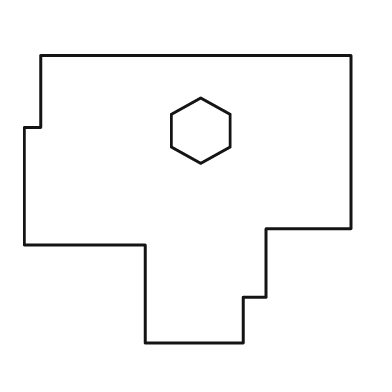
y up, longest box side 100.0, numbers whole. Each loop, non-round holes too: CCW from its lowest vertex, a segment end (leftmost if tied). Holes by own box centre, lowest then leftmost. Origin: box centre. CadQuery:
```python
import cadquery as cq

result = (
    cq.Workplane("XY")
    .moveTo(-13.0, -44.0)
    .lineTo(17.0, -44.0)
    .lineTo(17.0, -30.0)
    .lineTo(24.0, -30.0)
    .lineTo(24.0, -9.0)
    .lineTo(50.0, -9.0)
    .lineTo(50.0, 44.0)
    .lineTo(-45.0, 44.0)
    .lineTo(-45.0, 22.0)
    .lineTo(-50.0, 22.0)
    .lineTo(-50.0, -14.0)
    .lineTo(-13.0, -14.0)
    .close()
    .moveTo(4.0, 11.0)
    .lineTo(13.0, 16.0)
    .lineTo(13.0, 26.0)
    .lineTo(4.0, 31.0)
    .lineTo(-5.0, 26.0)
    .lineTo(-5.0, 16.0)
    .close()
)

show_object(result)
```